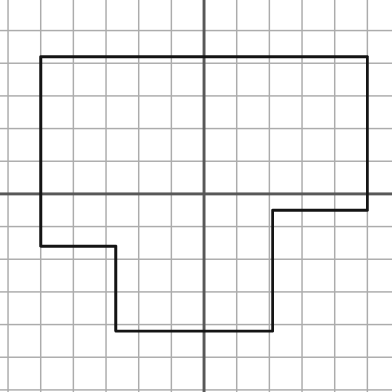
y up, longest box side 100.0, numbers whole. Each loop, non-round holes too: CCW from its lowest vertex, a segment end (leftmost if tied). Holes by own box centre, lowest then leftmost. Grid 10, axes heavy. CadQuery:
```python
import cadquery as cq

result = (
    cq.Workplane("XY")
    .moveTo(-27.0, -42.0)
    .lineTo(21.0, -42.0)
    .lineTo(21.0, -5.0)
    .lineTo(50.0, -5.0)
    .lineTo(50.0, 42.0)
    .lineTo(-50.0, 42.0)
    .lineTo(-50.0, -16.0)
    .lineTo(-27.0, -16.0)
    .close()
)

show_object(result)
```